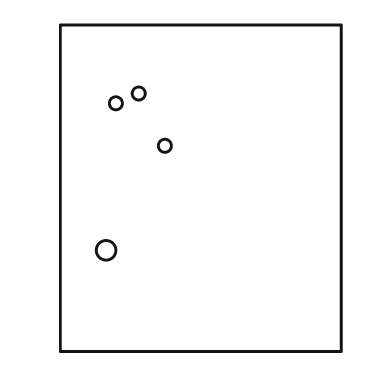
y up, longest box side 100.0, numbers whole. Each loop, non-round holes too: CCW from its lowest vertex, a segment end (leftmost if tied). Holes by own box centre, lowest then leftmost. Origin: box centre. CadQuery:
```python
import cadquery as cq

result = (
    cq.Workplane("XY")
    .moveTo(-43.0, -50.0)
    .lineTo(43.0, -50.0)
    .lineTo(43.0, 50.0)
    .lineTo(-43.0, 50.0)
    .close()
    .moveTo(-29.0, -19.0)
    .circle(3.0)
    .moveTo(-11.0, 13.0)
    .circle(2.0)
    .moveTo(-26.0, 26.0)
    .circle(2.0)
    .moveTo(-19.0, 29.0)
    .circle(2.0)
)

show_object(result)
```